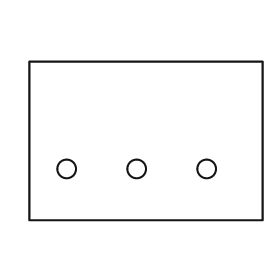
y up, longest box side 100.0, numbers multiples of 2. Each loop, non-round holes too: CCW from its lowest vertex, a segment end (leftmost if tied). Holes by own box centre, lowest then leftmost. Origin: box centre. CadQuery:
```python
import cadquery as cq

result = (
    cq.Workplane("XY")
    .moveTo(-50.0, -34.0)
    .lineTo(50.0, -34.0)
    .lineTo(50.0, 34.0)
    .lineTo(-50.0, 34.0)
    .close()
    .moveTo(-34.0, -12.0)
    .circle(4.0)
    .moveTo(-4.0, -12.0)
    .circle(4.0)
    .moveTo(26.0, -12.0)
    .circle(4.0)
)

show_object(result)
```